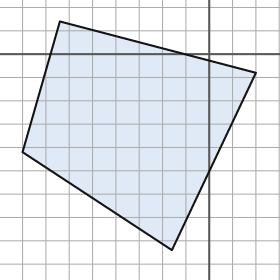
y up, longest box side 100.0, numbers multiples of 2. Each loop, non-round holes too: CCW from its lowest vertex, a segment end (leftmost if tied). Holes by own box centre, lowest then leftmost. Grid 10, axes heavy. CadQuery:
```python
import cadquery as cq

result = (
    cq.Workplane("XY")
    .moveTo(-16.0, -84.0)
    .lineTo(20.0, -8.0)
    .lineTo(-64.0, 14.0)
    .lineTo(-80.0, -42.0)
    .close()
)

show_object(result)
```